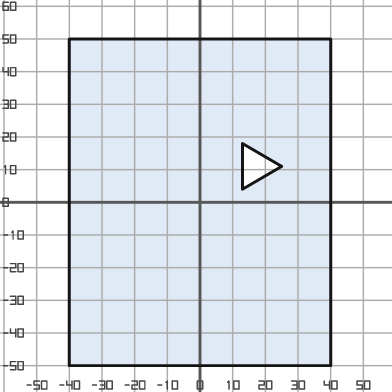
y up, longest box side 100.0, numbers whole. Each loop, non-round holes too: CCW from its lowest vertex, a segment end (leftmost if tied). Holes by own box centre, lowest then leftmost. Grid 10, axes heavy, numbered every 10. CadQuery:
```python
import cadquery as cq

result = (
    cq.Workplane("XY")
    .moveTo(-40.0, -50.0)
    .lineTo(40.0, -50.0)
    .lineTo(40.0, 50.0)
    .lineTo(-40.0, 50.0)
    .close()
    .moveTo(13.0, 4.0)
    .lineTo(25.0, 11.0)
    .lineTo(13.0, 18.0)
    .close()
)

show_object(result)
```